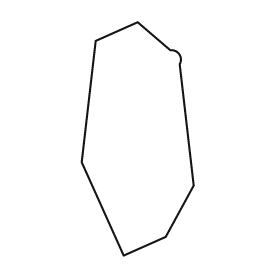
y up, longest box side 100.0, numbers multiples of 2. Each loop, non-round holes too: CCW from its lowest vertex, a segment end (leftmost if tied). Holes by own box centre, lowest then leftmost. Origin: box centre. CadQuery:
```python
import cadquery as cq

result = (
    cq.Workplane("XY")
    .moveTo(-6.0, -50.0)
    .lineTo(12.0, -42.0)
    .lineTo(24.0, -20.0)
    .lineTo(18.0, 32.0)
    .threePointArc((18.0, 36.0), (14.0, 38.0))
    .lineTo(0.0, 50.0)
    .lineTo(-18.0, 42.0)
    .lineTo(-24.0, -10.0)
    .close()
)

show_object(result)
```